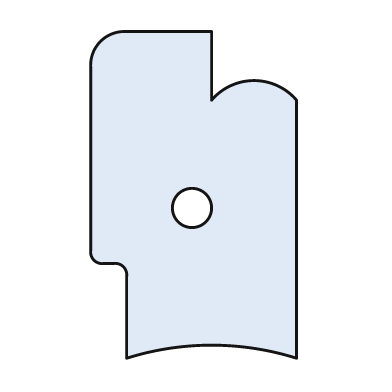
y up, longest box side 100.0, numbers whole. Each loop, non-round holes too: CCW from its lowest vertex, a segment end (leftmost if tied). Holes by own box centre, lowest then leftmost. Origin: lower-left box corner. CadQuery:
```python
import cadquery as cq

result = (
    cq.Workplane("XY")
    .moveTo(11.0, 0.0)
    .threePointArc((37.0, 4.0), (63.0, 0.0))
    .lineTo(63.0, 79.0)
    .threePointArc((50.0, 85.0), (37.0, 79.0))
    .lineTo(37.0, 100.0)
    .lineTo(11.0, 100.0)
    .threePointArc((3.0, 97.0), (0.0, 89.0))
    .lineTo(0.0, 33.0)
    .threePointArc((1.0, 30.0), (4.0, 29.0))
    .lineTo(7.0, 29.0)
    .threePointArc((10.0, 28.0), (11.0, 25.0))
    .close()
    .moveTo(31.0, 46.0)
    .circle(6.0)
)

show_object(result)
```